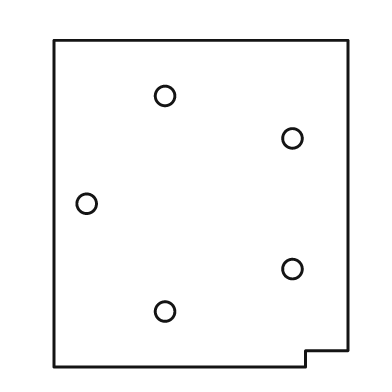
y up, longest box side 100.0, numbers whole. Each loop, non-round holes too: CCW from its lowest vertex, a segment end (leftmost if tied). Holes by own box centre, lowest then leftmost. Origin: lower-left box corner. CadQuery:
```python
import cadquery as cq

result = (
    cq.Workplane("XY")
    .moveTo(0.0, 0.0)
    .lineTo(77.0, 0.0)
    .lineTo(77.0, 5.0)
    .lineTo(90.0, 5.0)
    .lineTo(90.0, 100.0)
    .lineTo(0.0, 100.0)
    .close()
    .moveTo(34.0, 17.0)
    .circle(3.0)
    .moveTo(73.0, 30.0)
    .circle(3.0)
    .moveTo(10.0, 50.0)
    .circle(3.0)
    .moveTo(73.0, 70.0)
    .circle(3.0)
    .moveTo(34.0, 83.0)
    .circle(3.0)
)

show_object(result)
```